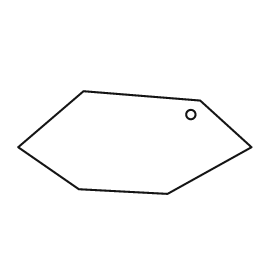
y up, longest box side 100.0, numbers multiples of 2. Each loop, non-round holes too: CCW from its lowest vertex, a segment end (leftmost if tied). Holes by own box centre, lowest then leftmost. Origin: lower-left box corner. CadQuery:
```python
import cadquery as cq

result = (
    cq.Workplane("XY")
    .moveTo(64.0, 0.0)
    .lineTo(100.0, 20.0)
    .lineTo(78.0, 40.0)
    .lineTo(28.0, 44.0)
    .lineTo(0.0, 20.0)
    .lineTo(26.0, 2.0)
    .close()
    .moveTo(74.0, 34.0)
    .circle(2.0)
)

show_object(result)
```